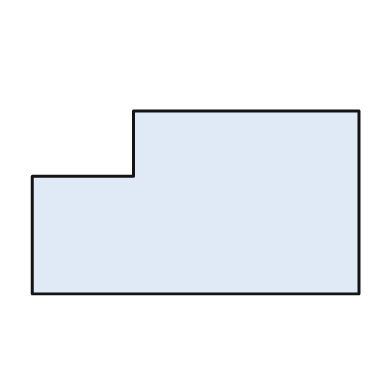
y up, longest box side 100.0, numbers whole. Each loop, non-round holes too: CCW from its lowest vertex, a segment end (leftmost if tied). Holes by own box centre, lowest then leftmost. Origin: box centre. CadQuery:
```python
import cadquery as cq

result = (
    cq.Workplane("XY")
    .moveTo(-50.0, -28.0)
    .lineTo(50.0, -28.0)
    .lineTo(50.0, 28.0)
    .lineTo(-19.0, 28.0)
    .lineTo(-19.0, 8.0)
    .lineTo(-50.0, 8.0)
    .close()
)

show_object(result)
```